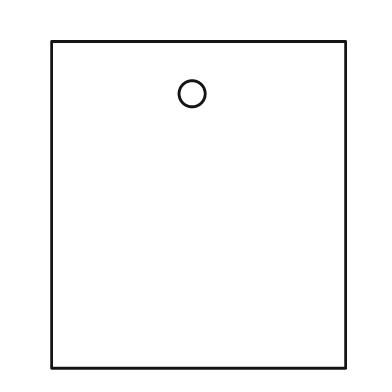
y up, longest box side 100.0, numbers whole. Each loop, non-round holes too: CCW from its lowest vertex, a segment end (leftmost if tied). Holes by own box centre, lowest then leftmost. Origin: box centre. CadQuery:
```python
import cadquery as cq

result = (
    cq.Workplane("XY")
    .moveTo(-45.0, -50.0)
    .lineTo(45.0, -50.0)
    .lineTo(45.0, 50.0)
    .lineTo(-45.0, 50.0)
    .close()
    .moveTo(-2.0, 34.0)
    .circle(4.0)
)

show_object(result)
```